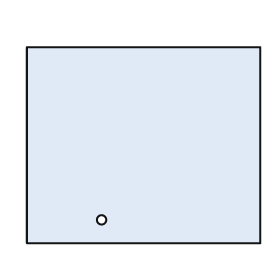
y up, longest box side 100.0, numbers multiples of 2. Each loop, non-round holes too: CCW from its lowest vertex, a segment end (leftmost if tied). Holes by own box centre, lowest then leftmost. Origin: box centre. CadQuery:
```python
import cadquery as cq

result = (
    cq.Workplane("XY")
    .moveTo(-50.0, -42.0)
    .lineTo(50.0, -42.0)
    .lineTo(50.0, 42.0)
    .lineTo(-50.0, 42.0)
    .close()
    .moveTo(-18.0, -32.0)
    .circle(2.0)
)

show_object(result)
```